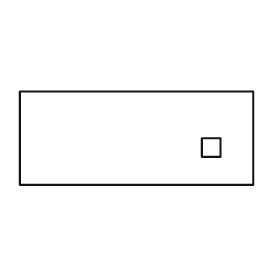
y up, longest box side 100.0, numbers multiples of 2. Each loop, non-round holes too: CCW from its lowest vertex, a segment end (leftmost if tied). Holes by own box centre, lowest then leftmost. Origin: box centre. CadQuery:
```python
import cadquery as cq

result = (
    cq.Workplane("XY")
    .moveTo(-50.0, -20.0)
    .lineTo(50.0, -20.0)
    .lineTo(50.0, 20.0)
    .lineTo(-50.0, 20.0)
    .close()
    .moveTo(28.0, -8.0)
    .lineTo(36.0, -8.0)
    .lineTo(36.0, 0.0)
    .lineTo(28.0, 0.0)
    .close()
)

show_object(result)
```